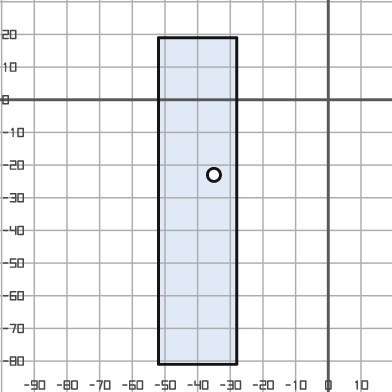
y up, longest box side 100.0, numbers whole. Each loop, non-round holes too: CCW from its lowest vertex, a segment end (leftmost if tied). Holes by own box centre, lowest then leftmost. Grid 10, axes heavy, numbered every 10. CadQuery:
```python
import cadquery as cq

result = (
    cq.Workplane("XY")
    .moveTo(-52.0, -81.0)
    .lineTo(-28.0, -81.0)
    .lineTo(-28.0, 19.0)
    .lineTo(-52.0, 19.0)
    .close()
    .moveTo(-35.0, -23.0)
    .circle(2.0)
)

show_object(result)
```